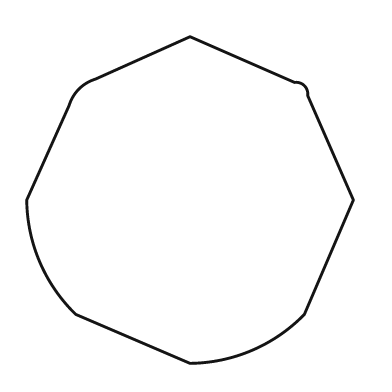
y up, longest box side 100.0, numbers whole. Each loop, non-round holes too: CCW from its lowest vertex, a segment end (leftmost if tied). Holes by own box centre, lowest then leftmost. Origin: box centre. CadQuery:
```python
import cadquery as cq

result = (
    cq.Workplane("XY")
    .moveTo(0.0, -50.0)
    .threePointArc((19.0, -46.0), (35.0, -35.0))
    .lineTo(50.0, 0.0)
    .lineTo(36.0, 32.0)
    .threePointArc((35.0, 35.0), (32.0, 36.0))
    .lineTo(0.0, 50.0)
    .lineTo(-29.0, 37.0)
    .threePointArc((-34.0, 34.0), (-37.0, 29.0))
    .lineTo(-50.0, 0.0)
    .threePointArc((-46.0, -19.0), (-35.0, -35.0))
    .close()
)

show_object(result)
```